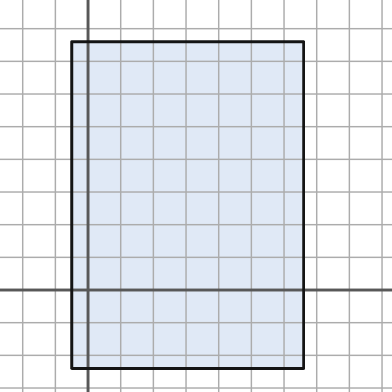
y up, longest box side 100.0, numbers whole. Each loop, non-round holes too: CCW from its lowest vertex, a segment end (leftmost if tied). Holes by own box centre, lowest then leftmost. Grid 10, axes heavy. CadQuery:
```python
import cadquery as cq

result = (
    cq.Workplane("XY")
    .moveTo(-5.0, -24.0)
    .lineTo(66.0, -24.0)
    .lineTo(66.0, 76.0)
    .lineTo(-5.0, 76.0)
    .close()
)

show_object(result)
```